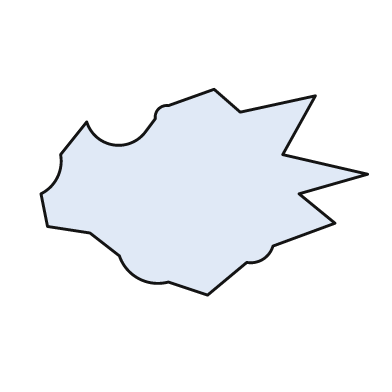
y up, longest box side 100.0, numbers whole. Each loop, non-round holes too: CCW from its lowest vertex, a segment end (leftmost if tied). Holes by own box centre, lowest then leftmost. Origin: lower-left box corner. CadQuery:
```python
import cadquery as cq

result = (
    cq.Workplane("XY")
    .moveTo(51.0, 0.0)
    .lineTo(63.0, 10.0)
    .threePointArc((68.0, 11.0), (71.0, 15.0))
    .lineTo(90.0, 22.0)
    .lineTo(79.0, 31.0)
    .lineTo(100.0, 37.0)
    .lineTo(74.0, 43.0)
    .lineTo(84.0, 61.0)
    .lineTo(61.0, 56.0)
    .lineTo(53.0, 63.0)
    .lineTo(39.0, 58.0)
    .threePointArc((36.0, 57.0), (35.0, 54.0))
    .lineTo(32.0, 50.0)
    .threePointArc((22.0, 46.0), (14.0, 53.0))
    .lineTo(6.0, 43.0)
    .threePointArc((5.0, 36.0), (0.0, 31.0))
    .lineTo(2.0, 21.0)
    .lineTo(15.0, 19.0)
    .lineTo(24.0, 12.0)
    .threePointArc((30.0, 5.0), (39.0, 4.0))
    .close()
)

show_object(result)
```